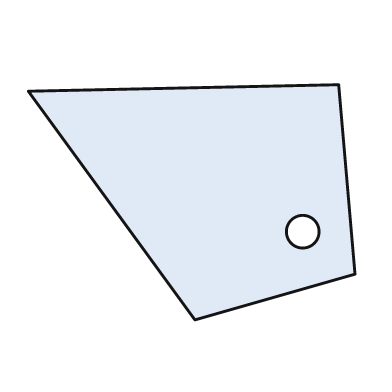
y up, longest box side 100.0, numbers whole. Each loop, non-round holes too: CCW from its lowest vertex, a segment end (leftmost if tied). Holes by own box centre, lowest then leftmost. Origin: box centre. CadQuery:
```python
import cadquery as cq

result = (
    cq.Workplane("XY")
    .moveTo(1.0, -36.0)
    .lineTo(50.0, -22.0)
    .lineTo(45.0, 36.0)
    .lineTo(-50.0, 34.0)
    .close()
    .moveTo(34.0, -9.0)
    .circle(5.0)
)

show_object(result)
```